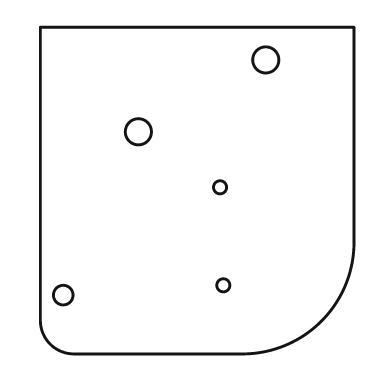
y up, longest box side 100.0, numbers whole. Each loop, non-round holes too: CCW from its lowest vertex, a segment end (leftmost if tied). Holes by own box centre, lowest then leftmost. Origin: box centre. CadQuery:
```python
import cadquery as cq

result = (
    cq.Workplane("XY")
    .moveTo(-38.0, -50.0)
    .lineTo(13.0, -50.0)
    .threePointArc((38.0, -40.0), (48.0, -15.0))
    .lineTo(48.0, 50.0)
    .lineTo(-48.0, 50.0)
    .lineTo(-48.0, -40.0)
    .threePointArc((-45.0, -47.0), (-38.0, -50.0))
    .close()
    .moveTo(-41.0, -32.0)
    .circle(3.0)
    .moveTo(8.0, -29.0)
    .circle(2.0)
    .moveTo(7.0, 1.0)
    .circle(2.0)
    .moveTo(-18.0, 18.0)
    .circle(4.0)
    .moveTo(21.0, 40.0)
    .circle(4.0)
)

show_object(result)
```